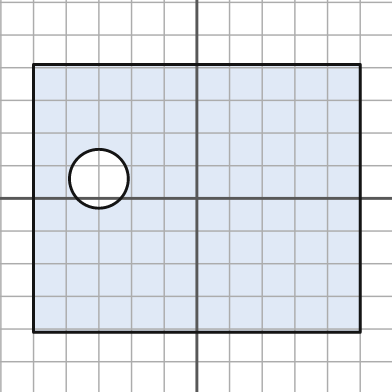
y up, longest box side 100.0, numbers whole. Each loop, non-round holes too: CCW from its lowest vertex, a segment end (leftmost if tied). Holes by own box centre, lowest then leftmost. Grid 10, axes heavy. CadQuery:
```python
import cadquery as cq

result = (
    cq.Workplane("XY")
    .moveTo(-50.0, -41.0)
    .lineTo(50.0, -41.0)
    .lineTo(50.0, 41.0)
    .lineTo(-50.0, 41.0)
    .close()
    .moveTo(-30.0, 6.0)
    .circle(9.0)
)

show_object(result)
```